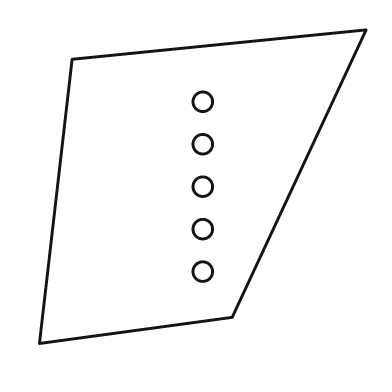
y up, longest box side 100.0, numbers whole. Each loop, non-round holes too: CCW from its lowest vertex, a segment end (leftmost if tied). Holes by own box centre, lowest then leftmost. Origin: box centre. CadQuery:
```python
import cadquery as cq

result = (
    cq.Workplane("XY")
    .moveTo(-50.0, -48.0)
    .lineTo(9.0, -40.0)
    .lineTo(50.0, 48.0)
    .lineTo(-40.0, 39.0)
    .close()
    .moveTo(0.0, -26.0)
    .circle(3.0)
    .moveTo(0.0, -13.0)
    .circle(3.0)
    .moveTo(0.0, 0.0)
    .circle(3.0)
    .moveTo(0.0, 13.0)
    .circle(3.0)
    .moveTo(0.0, 26.0)
    .circle(3.0)
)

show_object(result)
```